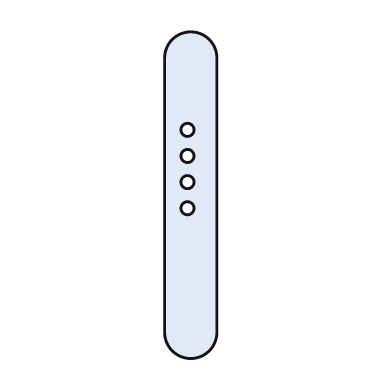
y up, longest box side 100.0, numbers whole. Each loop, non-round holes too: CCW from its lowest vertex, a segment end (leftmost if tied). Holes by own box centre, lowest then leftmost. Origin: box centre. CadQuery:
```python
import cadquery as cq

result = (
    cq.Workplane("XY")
    .moveTo(-8.0, -42.0)
    .threePointArc((0.0, -50.0), (8.0, -42.0))
    .lineTo(8.0, 42.0)
    .threePointArc((0.0, 50.0), (-8.0, 42.0))
    .close()
    .moveTo(-1.0, -4.0)
    .circle(2.0)
    .moveTo(-1.0, 4.0)
    .circle(2.0)
    .moveTo(-1.0, 12.0)
    .circle(2.0)
    .moveTo(-1.0, 20.0)
    .circle(2.0)
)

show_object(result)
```